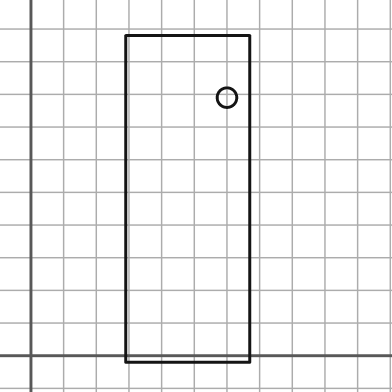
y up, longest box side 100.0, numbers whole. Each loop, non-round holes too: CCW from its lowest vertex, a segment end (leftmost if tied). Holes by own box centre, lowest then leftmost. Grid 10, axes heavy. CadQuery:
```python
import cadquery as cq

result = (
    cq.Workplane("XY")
    .moveTo(29.0, -2.0)
    .lineTo(67.0, -2.0)
    .lineTo(67.0, 98.0)
    .lineTo(29.0, 98.0)
    .close()
    .moveTo(60.0, 79.0)
    .circle(3.0)
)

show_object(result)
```